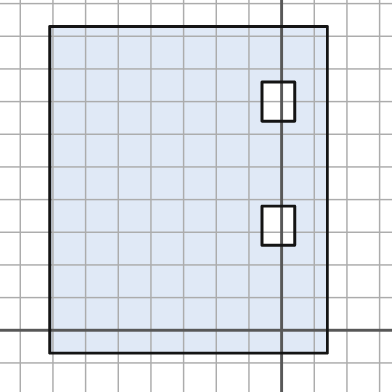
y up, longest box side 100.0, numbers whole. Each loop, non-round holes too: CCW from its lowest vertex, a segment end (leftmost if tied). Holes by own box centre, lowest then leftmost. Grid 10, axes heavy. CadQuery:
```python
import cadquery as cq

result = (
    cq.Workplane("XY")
    .moveTo(-71.0, -7.0)
    .lineTo(14.0, -7.0)
    .lineTo(14.0, 93.0)
    .lineTo(-71.0, 93.0)
    .close()
    .moveTo(-6.0, 26.0)
    .lineTo(4.0, 26.0)
    .lineTo(4.0, 38.0)
    .lineTo(-6.0, 38.0)
    .close()
    .moveTo(-6.0, 64.0)
    .lineTo(4.0, 64.0)
    .lineTo(4.0, 76.0)
    .lineTo(-6.0, 76.0)
    .close()
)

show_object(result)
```